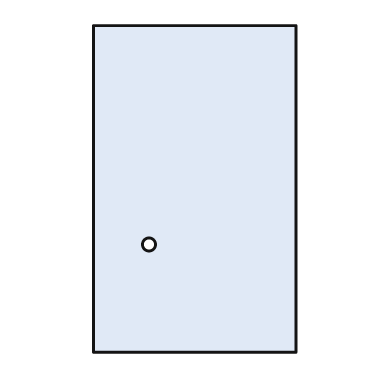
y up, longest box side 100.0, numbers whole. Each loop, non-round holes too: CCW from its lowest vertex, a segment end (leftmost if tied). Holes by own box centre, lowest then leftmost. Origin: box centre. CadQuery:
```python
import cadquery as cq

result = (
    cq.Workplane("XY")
    .moveTo(-31.0, -50.0)
    .lineTo(31.0, -50.0)
    .lineTo(31.0, 50.0)
    .lineTo(-31.0, 50.0)
    .close()
    .moveTo(-14.0, -17.0)
    .circle(2.0)
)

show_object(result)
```